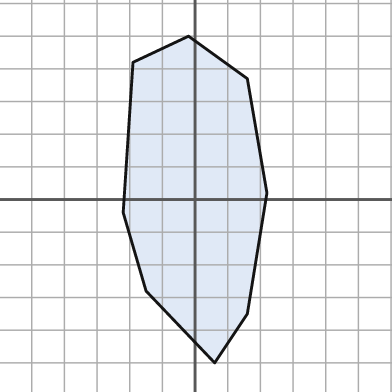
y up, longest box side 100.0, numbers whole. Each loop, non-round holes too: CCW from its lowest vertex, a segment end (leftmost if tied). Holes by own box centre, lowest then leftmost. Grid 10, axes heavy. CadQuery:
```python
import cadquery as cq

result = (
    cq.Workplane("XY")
    .moveTo(6.0, -50.0)
    .lineTo(16.0, -35.0)
    .lineTo(22.0, 2.0)
    .lineTo(16.0, 37.0)
    .lineTo(-2.0, 50.0)
    .lineTo(-19.0, 42.0)
    .lineTo(-22.0, -4.0)
    .lineTo(-15.0, -28.0)
    .close()
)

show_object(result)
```